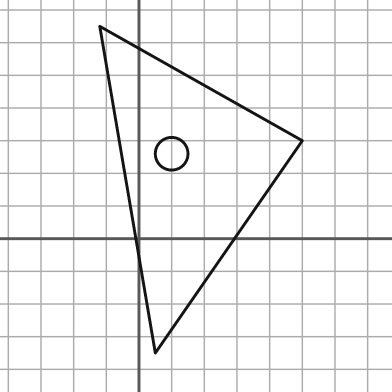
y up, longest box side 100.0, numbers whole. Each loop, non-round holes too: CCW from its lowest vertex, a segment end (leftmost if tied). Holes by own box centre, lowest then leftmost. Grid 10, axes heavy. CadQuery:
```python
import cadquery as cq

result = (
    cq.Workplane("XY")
    .moveTo(5.0, -35.0)
    .lineTo(50.0, 30.0)
    .lineTo(-12.0, 65.0)
    .close()
    .moveTo(10.0, 26.0)
    .circle(5.0)
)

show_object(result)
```